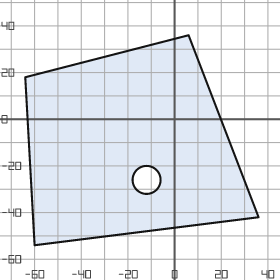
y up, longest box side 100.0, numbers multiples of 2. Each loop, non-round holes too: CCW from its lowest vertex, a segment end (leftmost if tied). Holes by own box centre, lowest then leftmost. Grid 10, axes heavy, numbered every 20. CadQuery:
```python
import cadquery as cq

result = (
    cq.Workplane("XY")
    .moveTo(-60.0, -54.0)
    .lineTo(36.0, -42.0)
    .lineTo(6.0, 36.0)
    .lineTo(-64.0, 18.0)
    .close()
    .moveTo(-12.0, -26.0)
    .circle(6.0)
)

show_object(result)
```